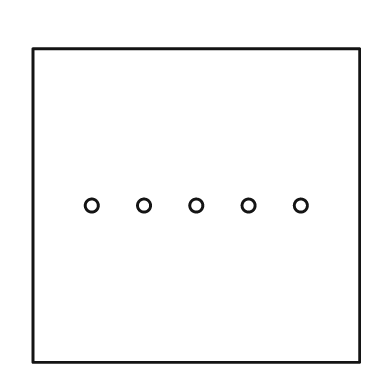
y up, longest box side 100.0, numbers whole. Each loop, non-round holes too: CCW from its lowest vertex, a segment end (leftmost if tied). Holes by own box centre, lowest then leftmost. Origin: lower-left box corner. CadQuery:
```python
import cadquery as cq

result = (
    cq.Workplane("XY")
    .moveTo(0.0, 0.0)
    .lineTo(100.0, 0.0)
    .lineTo(100.0, 96.0)
    .lineTo(0.0, 96.0)
    .close()
    .moveTo(18.0, 48.0)
    .circle(2.0)
    .moveTo(34.0, 48.0)
    .circle(2.0)
    .moveTo(50.0, 48.0)
    .circle(2.0)
    .moveTo(66.0, 48.0)
    .circle(2.0)
    .moveTo(82.0, 48.0)
    .circle(2.0)
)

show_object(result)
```